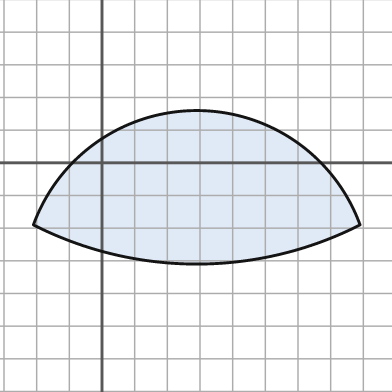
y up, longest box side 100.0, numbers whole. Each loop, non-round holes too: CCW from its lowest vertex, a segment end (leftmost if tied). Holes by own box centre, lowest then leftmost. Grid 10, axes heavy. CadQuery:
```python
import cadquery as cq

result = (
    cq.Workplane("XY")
    .moveTo(-21.0, -19.0)
    .threePointArc((29.0, -31.0), (79.0, -19.0))
    .threePointArc((29.0, 16.0), (-21.0, -19.0))
    .close()
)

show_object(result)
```